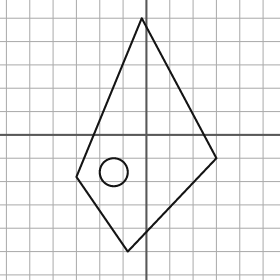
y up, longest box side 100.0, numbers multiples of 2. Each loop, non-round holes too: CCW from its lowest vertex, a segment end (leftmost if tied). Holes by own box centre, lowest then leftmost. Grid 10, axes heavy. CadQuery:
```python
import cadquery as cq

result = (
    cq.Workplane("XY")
    .moveTo(-8.0, -50.0)
    .lineTo(30.0, -10.0)
    .lineTo(-2.0, 50.0)
    .lineTo(-30.0, -18.0)
    .close()
    .moveTo(-14.0, -16.0)
    .circle(6.0)
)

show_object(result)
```